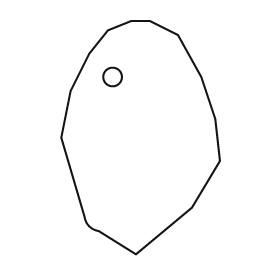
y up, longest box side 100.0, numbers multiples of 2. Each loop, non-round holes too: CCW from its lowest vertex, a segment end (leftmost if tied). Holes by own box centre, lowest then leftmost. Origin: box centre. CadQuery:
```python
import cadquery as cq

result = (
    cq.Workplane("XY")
    .moveTo(-2.0, -50.0)
    .lineTo(22.0, -30.0)
    .lineTo(34.0, -10.0)
    .lineTo(32.0, 8.0)
    .lineTo(26.0, 26.0)
    .lineTo(16.0, 44.0)
    .lineTo(4.0, 50.0)
    .lineTo(-4.0, 50.0)
    .lineTo(-14.0, 46.0)
    .lineTo(-22.0, 36.0)
    .lineTo(-30.0, 20.0)
    .lineTo(-34.0, 0.0)
    .lineTo(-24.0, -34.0)
    .threePointArc((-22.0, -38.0), (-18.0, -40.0))
    .close()
    .moveTo(-12.0, 26.0)
    .circle(4.0)
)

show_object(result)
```